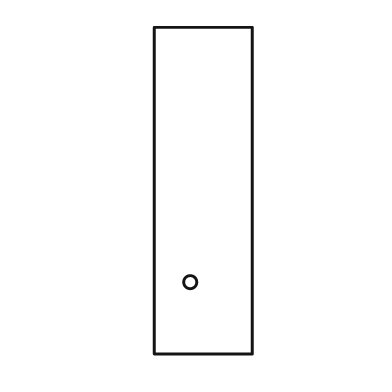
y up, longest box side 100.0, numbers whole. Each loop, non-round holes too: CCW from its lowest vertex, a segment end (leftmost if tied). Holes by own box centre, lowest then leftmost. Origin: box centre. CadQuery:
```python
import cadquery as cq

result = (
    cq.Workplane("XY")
    .moveTo(-15.0, -50.0)
    .lineTo(15.0, -50.0)
    .lineTo(15.0, 50.0)
    .lineTo(-15.0, 50.0)
    .close()
    .moveTo(-4.0, -28.0)
    .circle(2.0)
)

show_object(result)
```